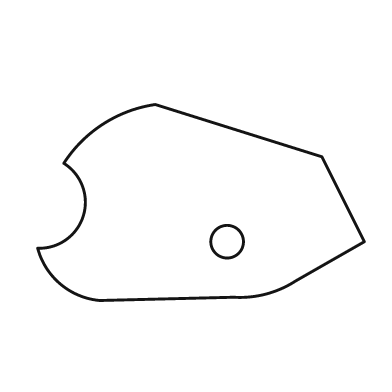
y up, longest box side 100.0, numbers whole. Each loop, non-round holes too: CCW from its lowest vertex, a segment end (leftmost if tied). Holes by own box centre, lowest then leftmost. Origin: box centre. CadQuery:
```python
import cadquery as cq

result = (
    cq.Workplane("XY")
    .moveTo(-31.0, -30.0)
    .lineTo(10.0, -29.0)
    .threePointArc((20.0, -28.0), (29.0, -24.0))
    .lineTo(50.0, -12.0)
    .lineTo(37.0, 14.0)
    .lineTo(-14.0, 30.0)
    .threePointArc((-30.0, 24.0), (-42.0, 12.0))
    .threePointArc((-36.0, -4.0), (-50.0, -14.0))
    .threePointArc((-43.0, -25.0), (-31.0, -30.0))
    .close()
    .moveTo(8.0, -12.0)
    .circle(5.0)
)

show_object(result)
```